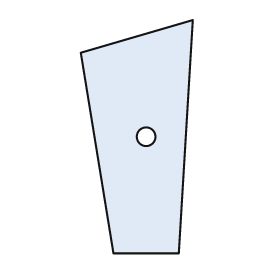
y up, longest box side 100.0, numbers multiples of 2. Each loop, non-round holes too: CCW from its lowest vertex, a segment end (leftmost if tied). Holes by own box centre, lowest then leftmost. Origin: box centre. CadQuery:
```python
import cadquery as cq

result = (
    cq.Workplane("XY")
    .moveTo(-10.0, -50.0)
    .lineTo(18.0, -50.0)
    .lineTo(24.0, 50.0)
    .lineTo(-24.0, 36.0)
    .close()
    .moveTo(4.0, 0.0)
    .circle(4.0)
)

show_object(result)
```